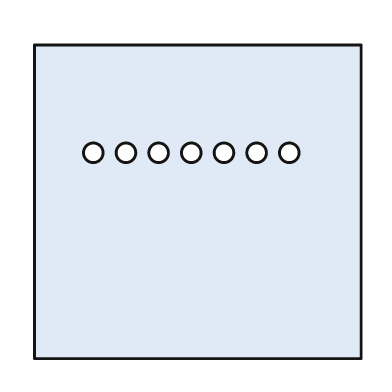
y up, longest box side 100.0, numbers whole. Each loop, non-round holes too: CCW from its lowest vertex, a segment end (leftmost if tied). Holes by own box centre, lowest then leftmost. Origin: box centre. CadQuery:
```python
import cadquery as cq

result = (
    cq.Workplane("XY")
    .moveTo(-50.0, -48.0)
    .lineTo(50.0, -48.0)
    .lineTo(50.0, 48.0)
    .lineTo(-50.0, 48.0)
    .close()
    .moveTo(-32.0, 15.0)
    .circle(3.0)
    .moveTo(-22.0, 15.0)
    .circle(3.0)
    .moveTo(-12.0, 15.0)
    .circle(3.0)
    .moveTo(-2.0, 15.0)
    .circle(3.0)
    .moveTo(8.0, 15.0)
    .circle(3.0)
    .moveTo(18.0, 15.0)
    .circle(3.0)
    .moveTo(28.0, 15.0)
    .circle(3.0)
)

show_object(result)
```